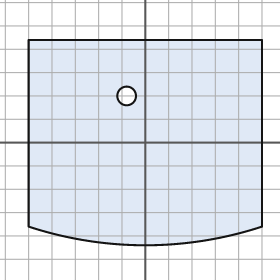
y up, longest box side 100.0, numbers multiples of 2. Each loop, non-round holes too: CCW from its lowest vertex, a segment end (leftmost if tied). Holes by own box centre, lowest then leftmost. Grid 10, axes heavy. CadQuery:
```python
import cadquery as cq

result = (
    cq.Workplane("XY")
    .moveTo(-50.0, -36.0)
    .threePointArc((0.0, -44.0), (50.0, -36.0))
    .lineTo(50.0, 44.0)
    .lineTo(-50.0, 44.0)
    .close()
    .moveTo(-8.0, 20.0)
    .circle(4.0)
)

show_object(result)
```